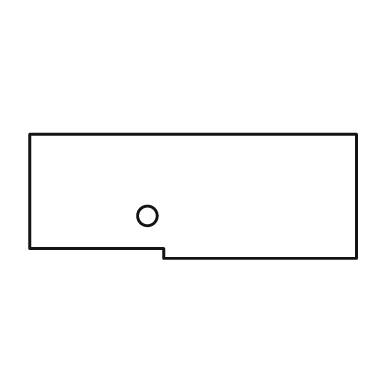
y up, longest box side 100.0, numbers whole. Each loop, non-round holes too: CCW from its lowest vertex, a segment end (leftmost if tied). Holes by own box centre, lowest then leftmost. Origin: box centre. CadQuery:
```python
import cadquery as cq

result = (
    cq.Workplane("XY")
    .moveTo(-9.0, -19.0)
    .lineTo(50.0, -19.0)
    .lineTo(50.0, 19.0)
    .lineTo(-50.0, 19.0)
    .lineTo(-50.0, -16.0)
    .lineTo(-9.0, -16.0)
    .close()
    .moveTo(-14.0, -6.0)
    .circle(3.0)
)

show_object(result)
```